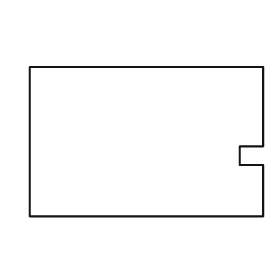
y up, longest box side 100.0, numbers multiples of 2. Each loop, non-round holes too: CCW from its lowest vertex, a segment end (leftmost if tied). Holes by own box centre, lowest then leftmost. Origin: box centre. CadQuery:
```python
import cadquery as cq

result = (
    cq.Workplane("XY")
    .moveTo(-50.0, -32.0)
    .lineTo(50.0, -32.0)
    .lineTo(50.0, -10.0)
    .lineTo(40.0, -10.0)
    .lineTo(40.0, -2.0)
    .lineTo(50.0, -2.0)
    .lineTo(50.0, 32.0)
    .lineTo(-50.0, 32.0)
    .close()
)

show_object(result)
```